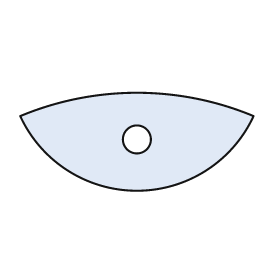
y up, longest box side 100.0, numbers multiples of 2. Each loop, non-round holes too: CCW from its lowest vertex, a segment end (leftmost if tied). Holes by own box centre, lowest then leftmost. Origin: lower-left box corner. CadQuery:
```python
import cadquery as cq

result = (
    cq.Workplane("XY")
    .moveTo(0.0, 32.0)
    .threePointArc((50.0, 0.0), (100.0, 32.0))
    .threePointArc((50.0, 42.0), (0.0, 32.0))
    .close()
    .moveTo(50.0, 22.0)
    .circle(6.0)
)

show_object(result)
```